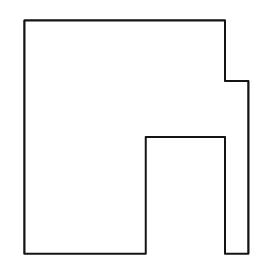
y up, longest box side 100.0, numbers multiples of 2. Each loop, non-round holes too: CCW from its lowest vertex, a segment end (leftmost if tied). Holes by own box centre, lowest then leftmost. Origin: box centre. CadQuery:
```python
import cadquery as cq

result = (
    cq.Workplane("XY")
    .moveTo(-48.0, -50.0)
    .lineTo(4.0, -50.0)
    .lineTo(4.0, 0.0)
    .lineTo(38.0, 0.0)
    .lineTo(38.0, -50.0)
    .lineTo(48.0, -50.0)
    .lineTo(48.0, 24.0)
    .lineTo(38.0, 24.0)
    .lineTo(38.0, 50.0)
    .lineTo(-48.0, 50.0)
    .close()
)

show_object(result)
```